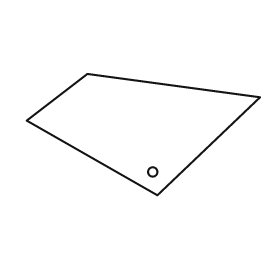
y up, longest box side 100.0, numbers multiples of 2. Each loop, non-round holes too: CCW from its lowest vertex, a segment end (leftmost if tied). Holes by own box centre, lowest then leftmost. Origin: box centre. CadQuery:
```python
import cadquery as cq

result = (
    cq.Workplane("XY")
    .moveTo(6.0, -26.0)
    .lineTo(50.0, 16.0)
    .lineTo(-24.0, 26.0)
    .lineTo(-50.0, 6.0)
    .close()
    .moveTo(4.0, -16.0)
    .circle(2.0)
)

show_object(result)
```